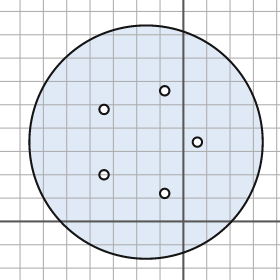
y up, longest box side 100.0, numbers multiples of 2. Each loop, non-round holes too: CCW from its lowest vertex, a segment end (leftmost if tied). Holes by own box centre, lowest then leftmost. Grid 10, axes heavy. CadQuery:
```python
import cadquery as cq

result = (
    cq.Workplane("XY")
    .moveTo(-16.0, 34.0)
    .circle(50.0)
    .moveTo(-8.0, 12.0)
    .circle(2.0)
    .moveTo(-34.0, 20.0)
    .circle(2.0)
    .moveTo(6.0, 34.0)
    .circle(2.0)
    .moveTo(-34.0, 48.0)
    .circle(2.0)
    .moveTo(-8.0, 56.0)
    .circle(2.0)
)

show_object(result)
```